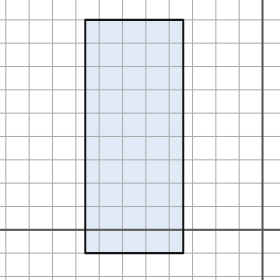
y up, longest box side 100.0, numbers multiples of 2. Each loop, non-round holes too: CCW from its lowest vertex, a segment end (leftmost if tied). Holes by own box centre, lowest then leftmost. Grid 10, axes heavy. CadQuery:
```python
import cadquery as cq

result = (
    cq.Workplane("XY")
    .moveTo(-76.0, -10.0)
    .lineTo(-34.0, -10.0)
    .lineTo(-34.0, 90.0)
    .lineTo(-76.0, 90.0)
    .close()
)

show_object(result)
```